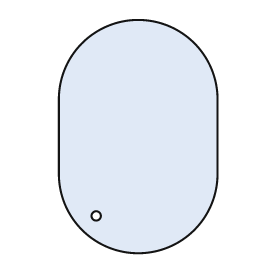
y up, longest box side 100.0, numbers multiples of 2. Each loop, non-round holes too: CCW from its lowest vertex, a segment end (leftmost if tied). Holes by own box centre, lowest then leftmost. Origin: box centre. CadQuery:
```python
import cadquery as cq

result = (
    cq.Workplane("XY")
    .moveTo(-34.0, -16.0)
    .threePointArc((0.0, -50.0), (34.0, -16.0))
    .lineTo(34.0, 16.0)
    .threePointArc((0.0, 50.0), (-34.0, 16.0))
    .close()
    .moveTo(-18.0, -34.0)
    .circle(2.0)
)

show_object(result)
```